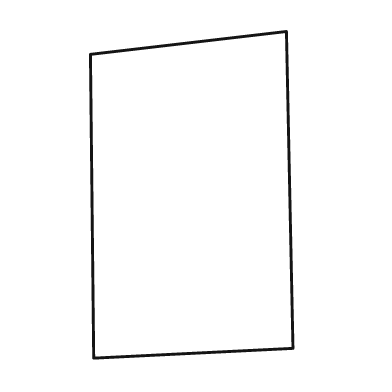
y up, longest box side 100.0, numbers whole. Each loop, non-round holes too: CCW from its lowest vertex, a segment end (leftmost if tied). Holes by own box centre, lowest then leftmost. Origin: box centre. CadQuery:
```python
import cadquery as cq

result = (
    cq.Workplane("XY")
    .moveTo(-30.0, -50.0)
    .lineTo(31.0, -47.0)
    .lineTo(29.0, 50.0)
    .lineTo(-31.0, 43.0)
    .close()
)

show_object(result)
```